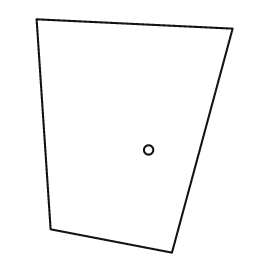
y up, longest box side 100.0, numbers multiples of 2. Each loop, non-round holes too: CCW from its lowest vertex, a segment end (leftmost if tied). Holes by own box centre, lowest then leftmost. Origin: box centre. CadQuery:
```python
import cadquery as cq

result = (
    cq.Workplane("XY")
    .moveTo(16.0, -50.0)
    .lineTo(42.0, 46.0)
    .lineTo(-42.0, 50.0)
    .lineTo(-36.0, -40.0)
    .close()
    .moveTo(6.0, -6.0)
    .circle(2.0)
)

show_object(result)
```